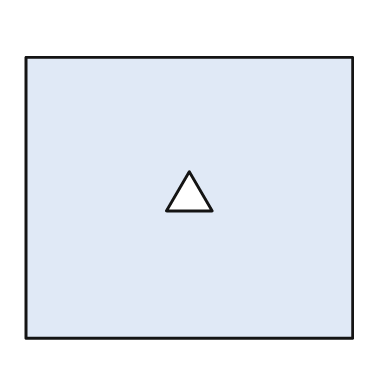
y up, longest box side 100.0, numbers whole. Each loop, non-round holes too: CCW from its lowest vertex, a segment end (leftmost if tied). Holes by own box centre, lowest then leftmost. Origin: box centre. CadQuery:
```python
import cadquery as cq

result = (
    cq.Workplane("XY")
    .moveTo(-50.0, -43.0)
    .lineTo(50.0, -43.0)
    .lineTo(50.0, 43.0)
    .lineTo(-50.0, 43.0)
    .close()
    .moveTo(-7.0, -4.0)
    .lineTo(7.0, -4.0)
    .lineTo(0.0, 8.0)
    .close()
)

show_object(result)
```